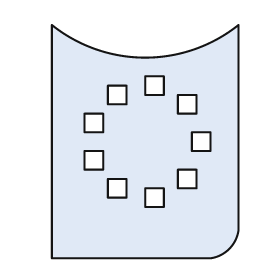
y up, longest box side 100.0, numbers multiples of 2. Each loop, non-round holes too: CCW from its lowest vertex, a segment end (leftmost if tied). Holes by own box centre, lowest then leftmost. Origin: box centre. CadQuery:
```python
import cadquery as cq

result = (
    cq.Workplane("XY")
    .moveTo(-40.0, -50.0)
    .lineTo(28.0, -50.0)
    .threePointArc((36.0, -46.0), (40.0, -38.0))
    .lineTo(40.0, 50.0)
    .threePointArc((0.0, 36.0), (-40.0, 50.0))
    .close()
    .moveTo(0.0, -28.0)
    .lineTo(8.0, -28.0)
    .lineTo(8.0, -20.0)
    .lineTo(0.0, -20.0)
    .close()
    .moveTo(-16.0, -24.0)
    .lineTo(-8.0, -24.0)
    .lineTo(-8.0, -16.0)
    .lineTo(-16.0, -16.0)
    .close()
    .moveTo(14.0, -20.0)
    .lineTo(22.0, -20.0)
    .lineTo(22.0, -12.0)
    .lineTo(14.0, -12.0)
    .close()
    .moveTo(-26.0, -12.0)
    .lineTo(-18.0, -12.0)
    .lineTo(-18.0, -4.0)
    .lineTo(-26.0, -4.0)
    .close()
    .moveTo(20.0, -4.0)
    .lineTo(28.0, -4.0)
    .lineTo(28.0, 4.0)
    .lineTo(20.0, 4.0)
    .close()
    .moveTo(-26.0, 4.0)
    .lineTo(-18.0, 4.0)
    .lineTo(-18.0, 12.0)
    .lineTo(-26.0, 12.0)
    .close()
    .moveTo(14.0, 12.0)
    .lineTo(22.0, 12.0)
    .lineTo(22.0, 20.0)
    .lineTo(14.0, 20.0)
    .close()
    .moveTo(-16.0, 16.0)
    .lineTo(-8.0, 16.0)
    .lineTo(-8.0, 24.0)
    .lineTo(-16.0, 24.0)
    .close()
    .moveTo(0.0, 20.0)
    .lineTo(8.0, 20.0)
    .lineTo(8.0, 28.0)
    .lineTo(0.0, 28.0)
    .close()
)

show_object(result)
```